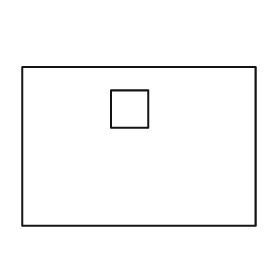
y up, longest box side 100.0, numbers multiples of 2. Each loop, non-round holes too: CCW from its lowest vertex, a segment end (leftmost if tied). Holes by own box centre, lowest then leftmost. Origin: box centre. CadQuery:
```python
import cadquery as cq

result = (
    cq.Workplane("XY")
    .moveTo(-50.0, -34.0)
    .lineTo(50.0, -34.0)
    .lineTo(50.0, 34.0)
    .lineTo(-50.0, 34.0)
    .close()
    .moveTo(-12.0, 8.0)
    .lineTo(4.0, 8.0)
    .lineTo(4.0, 24.0)
    .lineTo(-12.0, 24.0)
    .close()
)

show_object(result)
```